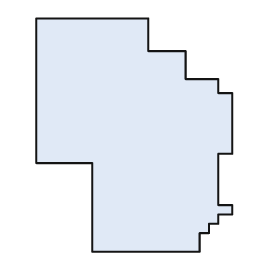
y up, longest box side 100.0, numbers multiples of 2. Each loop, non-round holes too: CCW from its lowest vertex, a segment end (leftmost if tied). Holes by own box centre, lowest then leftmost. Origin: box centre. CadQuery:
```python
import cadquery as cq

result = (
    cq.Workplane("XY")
    .moveTo(-18.0, -50.0)
    .lineTo(28.0, -50.0)
    .lineTo(28.0, -42.0)
    .lineTo(32.0, -42.0)
    .lineTo(32.0, -38.0)
    .lineTo(36.0, -38.0)
    .lineTo(36.0, -34.0)
    .lineTo(42.0, -34.0)
    .lineTo(42.0, -30.0)
    .lineTo(36.0, -30.0)
    .lineTo(36.0, -8.0)
    .lineTo(42.0, -8.0)
    .lineTo(42.0, 18.0)
    .lineTo(36.0, 18.0)
    .lineTo(36.0, 24.0)
    .lineTo(22.0, 24.0)
    .lineTo(22.0, 36.0)
    .lineTo(6.0, 36.0)
    .lineTo(6.0, 50.0)
    .lineTo(-42.0, 50.0)
    .lineTo(-42.0, -12.0)
    .lineTo(-18.0, -12.0)
    .close()
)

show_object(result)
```